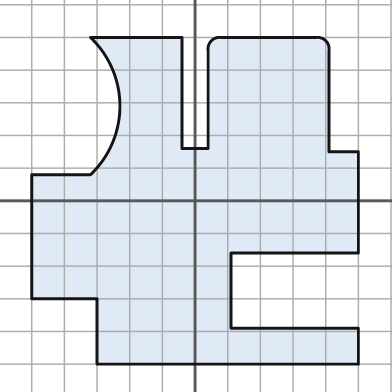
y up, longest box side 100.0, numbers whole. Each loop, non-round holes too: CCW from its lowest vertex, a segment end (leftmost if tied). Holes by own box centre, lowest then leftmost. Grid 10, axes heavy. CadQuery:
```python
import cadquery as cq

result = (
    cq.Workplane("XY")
    .moveTo(-30.0, -50.0)
    .lineTo(50.0, -50.0)
    .lineTo(50.0, -39.0)
    .lineTo(11.0, -39.0)
    .lineTo(11.0, -16.0)
    .lineTo(50.0, -16.0)
    .lineTo(50.0, 15.0)
    .lineTo(41.0, 15.0)
    .lineTo(41.0, 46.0)
    .threePointArc((40.0, 49.0), (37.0, 50.0))
    .lineTo(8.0, 50.0)
    .threePointArc((5.0, 49.0), (4.0, 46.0))
    .lineTo(4.0, 16.0)
    .lineTo(-4.0, 16.0)
    .lineTo(-4.0, 50.0)
    .lineTo(-32.0, 50.0)
    .threePointArc((-23.0, 29.0), (-32.0, 8.0))
    .lineTo(-50.0, 8.0)
    .lineTo(-50.0, -30.0)
    .lineTo(-30.0, -30.0)
    .close()
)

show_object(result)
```